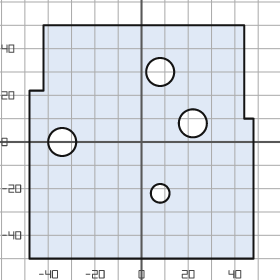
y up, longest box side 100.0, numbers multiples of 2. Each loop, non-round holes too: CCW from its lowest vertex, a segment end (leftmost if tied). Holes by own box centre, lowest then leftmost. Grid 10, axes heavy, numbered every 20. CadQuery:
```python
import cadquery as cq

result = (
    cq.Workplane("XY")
    .moveTo(-48.0, -50.0)
    .lineTo(48.0, -50.0)
    .lineTo(48.0, 10.0)
    .lineTo(44.0, 10.0)
    .lineTo(44.0, 50.0)
    .lineTo(-42.0, 50.0)
    .lineTo(-42.0, 22.0)
    .lineTo(-48.0, 22.0)
    .close()
    .moveTo(8.0, -22.0)
    .circle(4.0)
    .moveTo(-34.0, 0.0)
    .circle(6.0)
    .moveTo(22.0, 8.0)
    .circle(6.0)
    .moveTo(8.0, 30.0)
    .circle(6.0)
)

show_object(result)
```